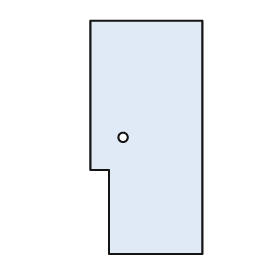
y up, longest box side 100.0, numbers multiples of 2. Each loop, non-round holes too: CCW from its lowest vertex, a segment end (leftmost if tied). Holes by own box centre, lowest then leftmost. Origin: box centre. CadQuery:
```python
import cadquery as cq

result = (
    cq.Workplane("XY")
    .moveTo(-16.0, -50.0)
    .lineTo(24.0, -50.0)
    .lineTo(24.0, 50.0)
    .lineTo(-24.0, 50.0)
    .lineTo(-24.0, -14.0)
    .lineTo(-16.0, -14.0)
    .close()
    .moveTo(-10.0, 0.0)
    .circle(2.0)
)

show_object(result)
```